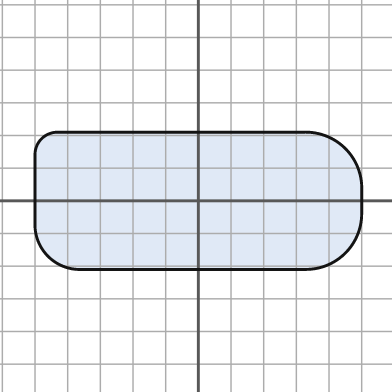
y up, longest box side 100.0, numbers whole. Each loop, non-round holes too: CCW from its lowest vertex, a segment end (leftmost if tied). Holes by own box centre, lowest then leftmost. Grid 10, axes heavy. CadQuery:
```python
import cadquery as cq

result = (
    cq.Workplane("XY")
    .moveTo(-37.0, -21.0)
    .lineTo(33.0, -21.0)
    .threePointArc((45.0, -16.0), (50.0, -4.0))
    .lineTo(50.0, 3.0)
    .threePointArc((45.0, 16.0), (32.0, 21.0))
    .lineTo(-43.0, 21.0)
    .threePointArc((-48.0, 19.0), (-50.0, 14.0))
    .lineTo(-50.0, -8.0)
    .threePointArc((-46.0, -17.0), (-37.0, -21.0))
    .close()
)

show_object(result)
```